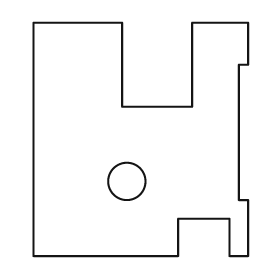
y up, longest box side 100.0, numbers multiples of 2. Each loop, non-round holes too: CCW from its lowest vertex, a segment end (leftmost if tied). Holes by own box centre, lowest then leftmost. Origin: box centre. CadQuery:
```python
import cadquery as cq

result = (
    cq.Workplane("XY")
    .moveTo(-46.0, -50.0)
    .lineTo(16.0, -50.0)
    .lineTo(16.0, -34.0)
    .lineTo(38.0, -34.0)
    .lineTo(38.0, -50.0)
    .lineTo(46.0, -50.0)
    .lineTo(46.0, -26.0)
    .lineTo(42.0, -26.0)
    .lineTo(42.0, 32.0)
    .lineTo(46.0, 32.0)
    .lineTo(46.0, 50.0)
    .lineTo(22.0, 50.0)
    .lineTo(22.0, 14.0)
    .lineTo(-8.0, 14.0)
    .lineTo(-8.0, 50.0)
    .lineTo(-46.0, 50.0)
    .close()
    .moveTo(-6.0, -18.0)
    .circle(8.0)
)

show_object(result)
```